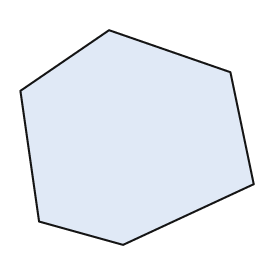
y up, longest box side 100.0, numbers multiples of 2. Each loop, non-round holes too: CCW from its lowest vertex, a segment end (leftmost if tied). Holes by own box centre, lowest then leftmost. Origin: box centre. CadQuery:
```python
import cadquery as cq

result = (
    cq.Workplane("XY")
    .moveTo(-6.0, -46.0)
    .lineTo(50.0, -20.0)
    .lineTo(40.0, 28.0)
    .lineTo(-12.0, 46.0)
    .lineTo(-50.0, 20.0)
    .lineTo(-42.0, -36.0)
    .close()
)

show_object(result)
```